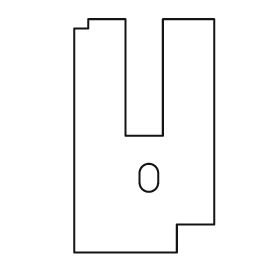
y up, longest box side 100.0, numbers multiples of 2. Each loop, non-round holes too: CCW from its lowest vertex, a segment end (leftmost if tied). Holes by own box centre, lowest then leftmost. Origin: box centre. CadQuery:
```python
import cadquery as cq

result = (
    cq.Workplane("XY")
    .moveTo(-30.0, -50.0)
    .lineTo(14.0, -50.0)
    .lineTo(14.0, -38.0)
    .lineTo(30.0, -38.0)
    .lineTo(30.0, 50.0)
    .lineTo(8.0, 50.0)
    .lineTo(8.0, 0.0)
    .lineTo(-8.0, 0.0)
    .lineTo(-8.0, 50.0)
    .lineTo(-24.0, 50.0)
    .lineTo(-24.0, 46.0)
    .lineTo(-30.0, 46.0)
    .close()
    .moveTo(-2.0, -20.0)
    .threePointArc((2.0, -24.0), (6.0, -20.0))
    .lineTo(6.0, -16.0)
    .threePointArc((2.0, -12.0), (-2.0, -16.0))
    .close()
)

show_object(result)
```